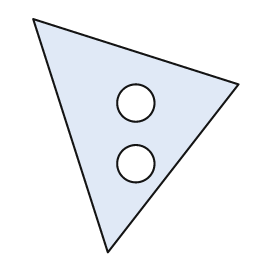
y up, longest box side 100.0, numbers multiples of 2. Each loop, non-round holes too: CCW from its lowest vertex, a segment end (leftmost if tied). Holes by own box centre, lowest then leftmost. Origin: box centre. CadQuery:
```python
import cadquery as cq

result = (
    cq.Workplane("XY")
    .moveTo(-12.0, -50.0)
    .lineTo(44.0, 22.0)
    .lineTo(-44.0, 50.0)
    .close()
    .moveTo(0.0, -12.0)
    .circle(8.0)
    .moveTo(0.0, 14.0)
    .circle(8.0)
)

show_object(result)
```